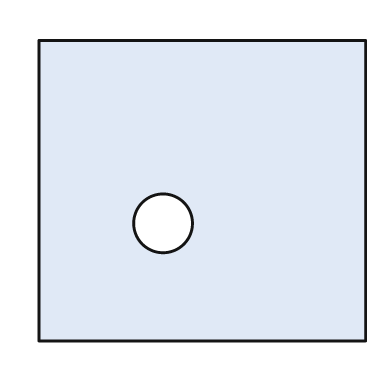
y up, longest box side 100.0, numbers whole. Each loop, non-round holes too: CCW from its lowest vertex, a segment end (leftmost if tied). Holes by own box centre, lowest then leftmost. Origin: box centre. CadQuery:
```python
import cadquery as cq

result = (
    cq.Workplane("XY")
    .moveTo(-50.0, -46.0)
    .lineTo(50.0, -46.0)
    .lineTo(50.0, 46.0)
    .lineTo(-50.0, 46.0)
    .close()
    .moveTo(-12.0, -10.0)
    .circle(9.0)
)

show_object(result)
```